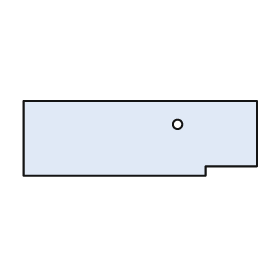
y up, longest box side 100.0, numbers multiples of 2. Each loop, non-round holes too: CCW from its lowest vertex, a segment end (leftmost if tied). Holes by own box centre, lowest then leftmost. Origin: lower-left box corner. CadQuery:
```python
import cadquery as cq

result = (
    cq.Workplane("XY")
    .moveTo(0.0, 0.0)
    .lineTo(78.0, 0.0)
    .lineTo(78.0, 4.0)
    .lineTo(100.0, 4.0)
    .lineTo(100.0, 32.0)
    .lineTo(0.0, 32.0)
    .close()
    .moveTo(66.0, 22.0)
    .circle(2.0)
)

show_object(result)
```